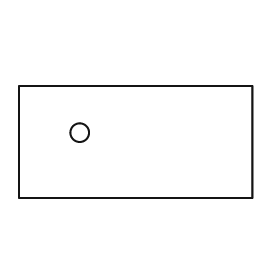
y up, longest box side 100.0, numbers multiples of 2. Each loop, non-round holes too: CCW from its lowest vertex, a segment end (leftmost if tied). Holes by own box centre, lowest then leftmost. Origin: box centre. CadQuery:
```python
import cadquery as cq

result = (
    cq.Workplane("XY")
    .moveTo(-50.0, -24.0)
    .lineTo(50.0, -24.0)
    .lineTo(50.0, 24.0)
    .lineTo(-50.0, 24.0)
    .close()
    .moveTo(-24.0, 4.0)
    .circle(4.0)
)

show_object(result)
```